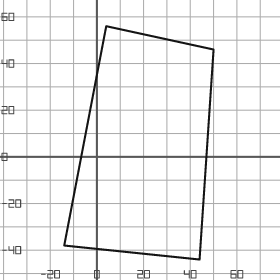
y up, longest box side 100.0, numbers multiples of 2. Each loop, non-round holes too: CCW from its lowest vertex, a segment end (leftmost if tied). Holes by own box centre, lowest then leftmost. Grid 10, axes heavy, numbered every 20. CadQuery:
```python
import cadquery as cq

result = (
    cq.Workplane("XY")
    .moveTo(44.0, -44.0)
    .lineTo(50.0, 46.0)
    .lineTo(4.0, 56.0)
    .lineTo(-14.0, -38.0)
    .close()
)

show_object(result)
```